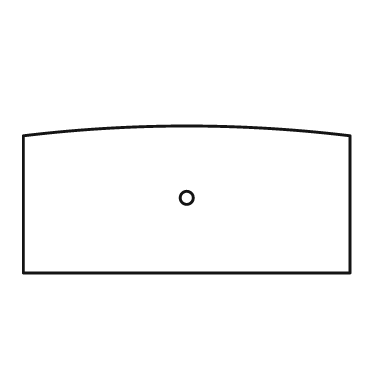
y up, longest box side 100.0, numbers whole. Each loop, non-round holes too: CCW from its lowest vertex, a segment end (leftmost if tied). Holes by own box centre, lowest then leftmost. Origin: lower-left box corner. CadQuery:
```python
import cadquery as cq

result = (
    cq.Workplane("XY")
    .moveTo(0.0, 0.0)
    .lineTo(100.0, 0.0)
    .lineTo(100.0, 42.0)
    .threePointArc((50.0, 45.0), (0.0, 42.0))
    .close()
    .moveTo(50.0, 23.0)
    .circle(2.0)
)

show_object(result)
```